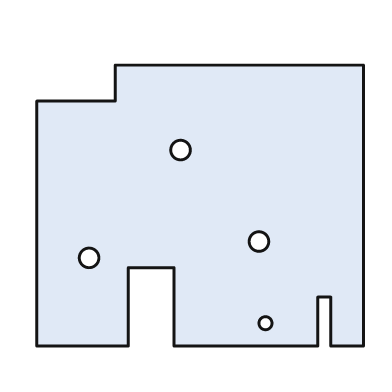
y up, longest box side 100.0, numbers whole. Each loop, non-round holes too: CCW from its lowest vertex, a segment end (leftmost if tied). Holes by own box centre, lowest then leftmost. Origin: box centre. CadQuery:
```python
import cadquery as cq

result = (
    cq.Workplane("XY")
    .moveTo(-50.0, -43.0)
    .lineTo(-22.0, -43.0)
    .lineTo(-22.0, -19.0)
    .lineTo(-8.0, -19.0)
    .lineTo(-8.0, -43.0)
    .lineTo(36.0, -43.0)
    .lineTo(36.0, -28.0)
    .lineTo(40.0, -28.0)
    .lineTo(40.0, -43.0)
    .lineTo(50.0, -43.0)
    .lineTo(50.0, 43.0)
    .lineTo(-26.0, 43.0)
    .lineTo(-26.0, 32.0)
    .lineTo(-50.0, 32.0)
    .close()
    .moveTo(20.0, -36.0)
    .circle(2.0)
    .moveTo(-34.0, -16.0)
    .circle(3.0)
    .moveTo(18.0, -11.0)
    .circle(3.0)
    .moveTo(-6.0, 17.0)
    .circle(3.0)
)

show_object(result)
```